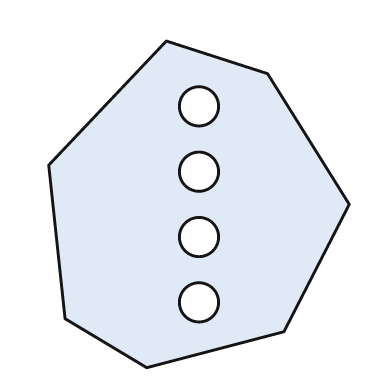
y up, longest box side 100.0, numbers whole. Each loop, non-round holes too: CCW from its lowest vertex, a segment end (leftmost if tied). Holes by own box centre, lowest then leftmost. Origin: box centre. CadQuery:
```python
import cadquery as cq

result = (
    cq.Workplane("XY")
    .moveTo(-16.0, -50.0)
    .lineTo(26.0, -39.0)
    .lineTo(46.0, 0.0)
    .lineTo(21.0, 40.0)
    .lineTo(-10.0, 50.0)
    .lineTo(-46.0, 12.0)
    .lineTo(-41.0, -35.0)
    .close()
    .moveTo(0.0, -30.0)
    .circle(6.0)
    .moveTo(0.0, -10.0)
    .circle(6.0)
    .moveTo(0.0, 10.0)
    .circle(6.0)
    .moveTo(0.0, 30.0)
    .circle(6.0)
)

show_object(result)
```